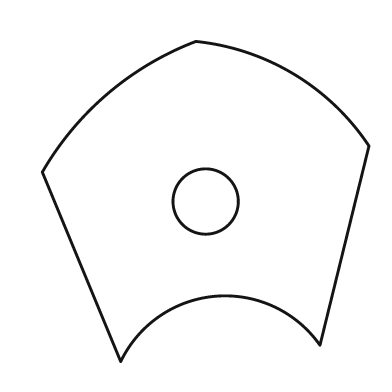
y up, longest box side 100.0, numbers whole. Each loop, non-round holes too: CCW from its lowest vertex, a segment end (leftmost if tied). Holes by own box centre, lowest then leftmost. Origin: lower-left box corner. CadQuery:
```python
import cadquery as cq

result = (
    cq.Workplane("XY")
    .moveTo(24.0, 0.0)
    .threePointArc((53.0, 20.0), (85.0, 5.0))
    .lineTo(100.0, 66.0)
    .threePointArc((77.0, 88.0), (47.0, 98.0))
    .threePointArc((20.0, 82.0), (0.0, 58.0))
    .close()
    .moveTo(50.0, 49.0)
    .circle(10.0)
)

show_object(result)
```